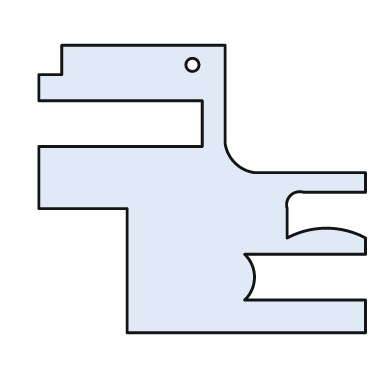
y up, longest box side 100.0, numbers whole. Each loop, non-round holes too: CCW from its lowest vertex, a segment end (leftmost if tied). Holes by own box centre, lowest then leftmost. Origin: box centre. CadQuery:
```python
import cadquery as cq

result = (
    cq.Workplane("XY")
    .moveTo(-23.0, -44.0)
    .lineTo(50.0, -44.0)
    .lineTo(50.0, -34.0)
    .lineTo(13.0, -34.0)
    .threePointArc((16.0, -27.0), (13.0, -20.0))
    .lineTo(50.0, -20.0)
    .lineTo(50.0, -15.0)
    .threePointArc((38.0, -12.0), (26.0, -15.0))
    .lineTo(26.0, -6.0)
    .threePointArc((27.0, -2.0), (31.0, -1.0))
    .lineTo(50.0, -1.0)
    .lineTo(50.0, 5.0)
    .lineTo(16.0, 5.0)
    .threePointArc((10.0, 8.0), (7.0, 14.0))
    .lineTo(7.0, 44.0)
    .lineTo(-43.0, 44.0)
    .lineTo(-43.0, 35.0)
    .lineTo(-50.0, 35.0)
    .lineTo(-50.0, 27.0)
    .lineTo(0.0, 27.0)
    .lineTo(0.0, 13.0)
    .lineTo(-50.0, 13.0)
    .lineTo(-50.0, -6.0)
    .lineTo(-23.0, -6.0)
    .close()
    .moveTo(-3.0, 38.0)
    .circle(2.0)
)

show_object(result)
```